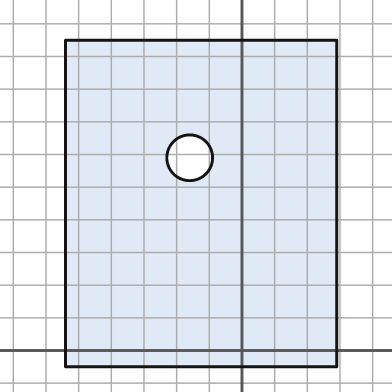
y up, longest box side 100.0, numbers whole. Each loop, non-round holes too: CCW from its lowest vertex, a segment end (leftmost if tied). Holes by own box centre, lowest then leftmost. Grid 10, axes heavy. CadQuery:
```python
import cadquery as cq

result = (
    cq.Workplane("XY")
    .moveTo(-54.0, -5.0)
    .lineTo(29.0, -5.0)
    .lineTo(29.0, 95.0)
    .lineTo(-54.0, 95.0)
    .close()
    .moveTo(-16.0, 59.0)
    .circle(7.0)
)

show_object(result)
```